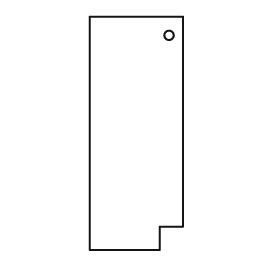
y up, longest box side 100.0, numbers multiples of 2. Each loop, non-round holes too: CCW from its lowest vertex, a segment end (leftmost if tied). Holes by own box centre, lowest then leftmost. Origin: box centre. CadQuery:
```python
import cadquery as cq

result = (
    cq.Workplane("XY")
    .moveTo(-20.0, -50.0)
    .lineTo(10.0, -50.0)
    .lineTo(10.0, -40.0)
    .lineTo(20.0, -40.0)
    .lineTo(20.0, 50.0)
    .lineTo(-20.0, 50.0)
    .close()
    .moveTo(14.0, 42.0)
    .circle(2.0)
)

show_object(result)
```